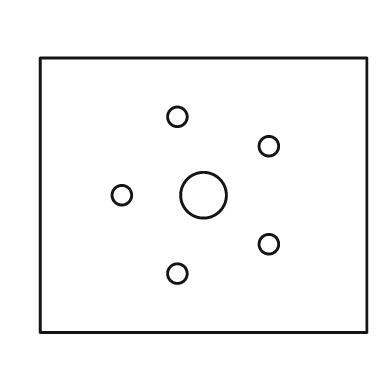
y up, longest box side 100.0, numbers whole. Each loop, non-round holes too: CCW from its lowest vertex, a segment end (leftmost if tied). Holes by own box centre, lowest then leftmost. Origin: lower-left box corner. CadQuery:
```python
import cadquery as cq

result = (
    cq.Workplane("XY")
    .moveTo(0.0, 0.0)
    .lineTo(100.0, 0.0)
    .lineTo(100.0, 84.0)
    .lineTo(0.0, 84.0)
    .close()
    .moveTo(42.0, 18.0)
    .circle(3.0)
    .moveTo(70.0, 27.0)
    .circle(3.0)
    .moveTo(25.0, 42.0)
    .circle(3.0)
    .moveTo(50.0, 42.0)
    .circle(7.0)
    .moveTo(70.0, 57.0)
    .circle(3.0)
    .moveTo(42.0, 66.0)
    .circle(3.0)
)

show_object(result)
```